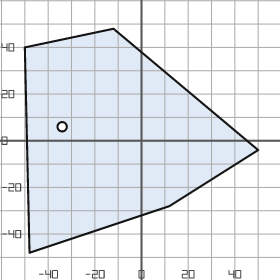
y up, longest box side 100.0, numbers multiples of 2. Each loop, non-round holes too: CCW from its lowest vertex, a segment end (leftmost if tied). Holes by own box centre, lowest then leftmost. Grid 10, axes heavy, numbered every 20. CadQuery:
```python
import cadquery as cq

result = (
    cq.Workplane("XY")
    .moveTo(-48.0, -48.0)
    .lineTo(12.0, -28.0)
    .lineTo(50.0, -4.0)
    .lineTo(-12.0, 48.0)
    .lineTo(-50.0, 40.0)
    .close()
    .moveTo(-34.0, 6.0)
    .circle(2.0)
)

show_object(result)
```